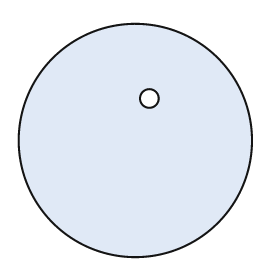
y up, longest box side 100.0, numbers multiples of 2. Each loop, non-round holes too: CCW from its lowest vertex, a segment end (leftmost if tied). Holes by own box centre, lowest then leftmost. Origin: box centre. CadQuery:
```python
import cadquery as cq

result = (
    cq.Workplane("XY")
    .moveTo(0.0, 0.0)
    .circle(50.0)
    .moveTo(6.0, 18.0)
    .circle(4.0)
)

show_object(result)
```